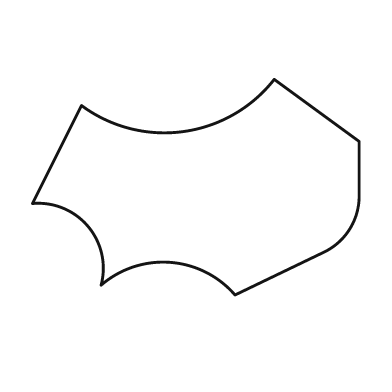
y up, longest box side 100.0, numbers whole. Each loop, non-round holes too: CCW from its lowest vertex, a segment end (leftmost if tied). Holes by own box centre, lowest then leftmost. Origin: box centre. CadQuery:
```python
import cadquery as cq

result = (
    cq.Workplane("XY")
    .moveTo(12.0, -33.0)
    .lineTo(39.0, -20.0)
    .threePointArc((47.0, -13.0), (50.0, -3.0))
    .lineTo(50.0, 14.0)
    .lineTo(24.0, 33.0)
    .threePointArc((-4.0, 17.0), (-35.0, 25.0))
    .lineTo(-50.0, -5.0)
    .threePointArc((-33.0, -12.0), (-29.0, -30.0))
    .threePointArc((-8.0, -23.0), (12.0, -33.0))
    .close()
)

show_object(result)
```